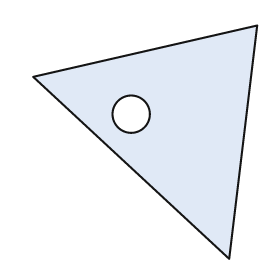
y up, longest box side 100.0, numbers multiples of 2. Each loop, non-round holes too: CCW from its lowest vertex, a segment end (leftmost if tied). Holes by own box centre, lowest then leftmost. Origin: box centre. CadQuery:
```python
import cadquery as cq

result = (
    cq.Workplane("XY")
    .moveTo(36.0, -50.0)
    .lineTo(48.0, 50.0)
    .lineTo(-48.0, 28.0)
    .close()
    .moveTo(-6.0, 12.0)
    .circle(8.0)
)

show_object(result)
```